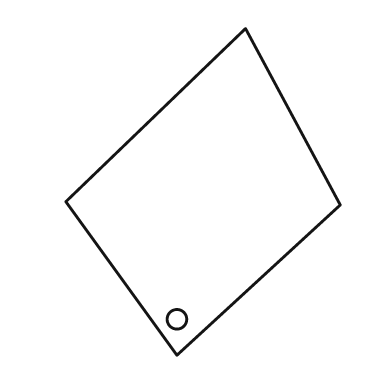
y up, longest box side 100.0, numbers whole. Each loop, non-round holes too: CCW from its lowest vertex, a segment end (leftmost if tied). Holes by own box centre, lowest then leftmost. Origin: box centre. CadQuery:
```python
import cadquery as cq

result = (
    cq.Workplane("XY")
    .moveTo(-8.0, -50.0)
    .lineTo(42.0, -4.0)
    .lineTo(13.0, 50.0)
    .lineTo(-42.0, -3.0)
    .close()
    .moveTo(-8.0, -39.0)
    .circle(3.0)
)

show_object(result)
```